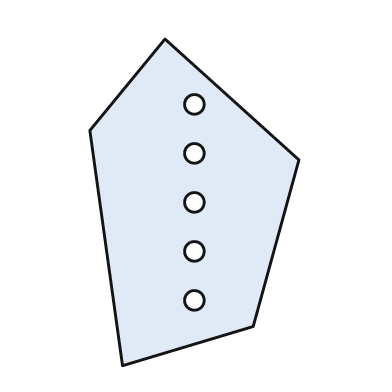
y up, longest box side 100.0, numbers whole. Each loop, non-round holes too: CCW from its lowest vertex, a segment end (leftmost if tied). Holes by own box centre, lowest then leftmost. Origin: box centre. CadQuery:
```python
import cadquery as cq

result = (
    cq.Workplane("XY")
    .moveTo(-22.0, -50.0)
    .lineTo(18.0, -38.0)
    .lineTo(32.0, 13.0)
    .lineTo(-9.0, 50.0)
    .lineTo(-32.0, 22.0)
    .close()
    .moveTo(0.0, -30.0)
    .circle(3.0)
    .moveTo(0.0, -15.0)
    .circle(3.0)
    .moveTo(0.0, 0.0)
    .circle(3.0)
    .moveTo(0.0, 15.0)
    .circle(3.0)
    .moveTo(0.0, 30.0)
    .circle(3.0)
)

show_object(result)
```